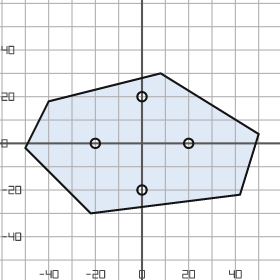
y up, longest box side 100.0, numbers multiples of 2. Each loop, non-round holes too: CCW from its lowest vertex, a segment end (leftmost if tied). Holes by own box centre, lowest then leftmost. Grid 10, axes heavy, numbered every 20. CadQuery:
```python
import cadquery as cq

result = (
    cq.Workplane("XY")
    .moveTo(-22.0, -30.0)
    .lineTo(42.0, -22.0)
    .lineTo(50.0, 4.0)
    .lineTo(8.0, 30.0)
    .lineTo(-40.0, 18.0)
    .lineTo(-50.0, -2.0)
    .close()
    .moveTo(0.0, -20.0)
    .circle(2.0)
    .moveTo(-20.0, 0.0)
    .circle(2.0)
    .moveTo(20.0, 0.0)
    .circle(2.0)
    .moveTo(0.0, 20.0)
    .circle(2.0)
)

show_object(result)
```